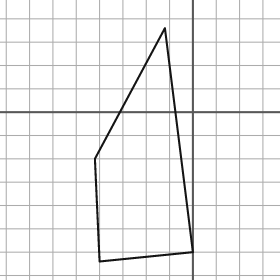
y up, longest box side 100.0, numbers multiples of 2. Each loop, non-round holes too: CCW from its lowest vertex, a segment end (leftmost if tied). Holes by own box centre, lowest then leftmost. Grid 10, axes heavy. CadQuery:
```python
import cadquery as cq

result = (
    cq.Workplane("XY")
    .moveTo(-40.0, -64.0)
    .lineTo(0.0, -60.0)
    .lineTo(-12.0, 36.0)
    .lineTo(-42.0, -20.0)
    .close()
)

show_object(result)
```